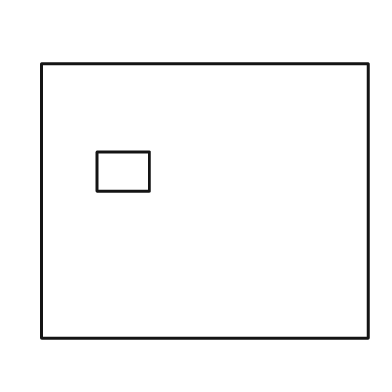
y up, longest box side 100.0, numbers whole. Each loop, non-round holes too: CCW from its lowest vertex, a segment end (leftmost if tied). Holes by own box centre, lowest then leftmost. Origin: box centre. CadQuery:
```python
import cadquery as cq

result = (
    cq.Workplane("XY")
    .moveTo(-50.0, -42.0)
    .lineTo(50.0, -42.0)
    .lineTo(50.0, 42.0)
    .lineTo(-50.0, 42.0)
    .close()
    .moveTo(-33.0, 3.0)
    .lineTo(-17.0, 3.0)
    .lineTo(-17.0, 15.0)
    .lineTo(-33.0, 15.0)
    .close()
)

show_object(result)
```